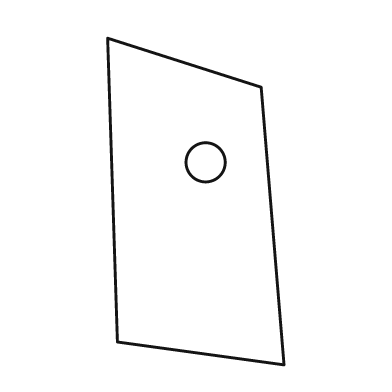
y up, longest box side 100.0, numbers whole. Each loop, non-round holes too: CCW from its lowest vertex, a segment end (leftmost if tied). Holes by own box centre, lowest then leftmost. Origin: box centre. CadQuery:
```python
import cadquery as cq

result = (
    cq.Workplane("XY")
    .moveTo(27.0, -50.0)
    .lineTo(20.0, 35.0)
    .lineTo(-27.0, 50.0)
    .lineTo(-24.0, -43.0)
    .close()
    .moveTo(3.0, 12.0)
    .circle(6.0)
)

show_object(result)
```